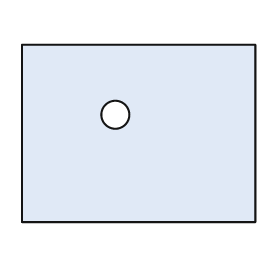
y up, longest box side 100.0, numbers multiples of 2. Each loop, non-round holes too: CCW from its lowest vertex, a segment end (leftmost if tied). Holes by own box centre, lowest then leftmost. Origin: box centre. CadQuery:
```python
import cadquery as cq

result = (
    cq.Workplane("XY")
    .moveTo(-50.0, -38.0)
    .lineTo(50.0, -38.0)
    .lineTo(50.0, 38.0)
    .lineTo(-50.0, 38.0)
    .close()
    .moveTo(-10.0, 8.0)
    .circle(6.0)
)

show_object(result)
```